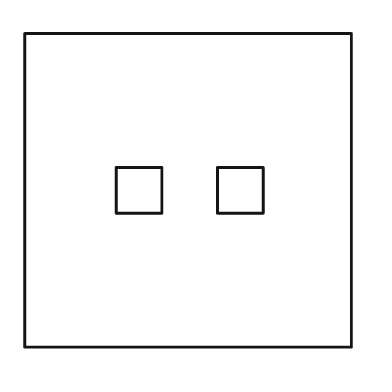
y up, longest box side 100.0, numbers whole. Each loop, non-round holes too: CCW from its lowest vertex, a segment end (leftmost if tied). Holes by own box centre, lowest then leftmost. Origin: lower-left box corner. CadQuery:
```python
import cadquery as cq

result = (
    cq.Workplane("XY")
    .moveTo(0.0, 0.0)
    .lineTo(100.0, 0.0)
    .lineTo(100.0, 96.0)
    .lineTo(0.0, 96.0)
    .close()
    .moveTo(28.0, 41.0)
    .lineTo(42.0, 41.0)
    .lineTo(42.0, 55.0)
    .lineTo(28.0, 55.0)
    .close()
    .moveTo(59.0, 41.0)
    .lineTo(73.0, 41.0)
    .lineTo(73.0, 55.0)
    .lineTo(59.0, 55.0)
    .close()
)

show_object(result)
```